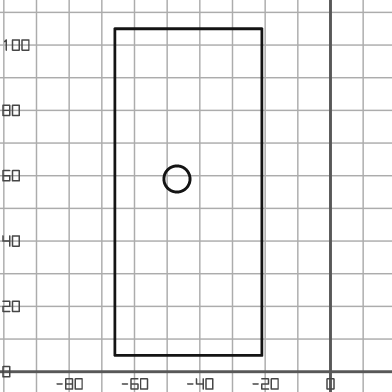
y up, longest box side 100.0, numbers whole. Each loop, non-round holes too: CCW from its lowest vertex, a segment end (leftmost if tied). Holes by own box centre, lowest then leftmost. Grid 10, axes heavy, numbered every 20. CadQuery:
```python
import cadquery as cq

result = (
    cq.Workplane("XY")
    .moveTo(-66.0, 5.0)
    .lineTo(-21.0, 5.0)
    .lineTo(-21.0, 105.0)
    .lineTo(-66.0, 105.0)
    .close()
    .moveTo(-47.0, 59.0)
    .circle(4.0)
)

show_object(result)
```